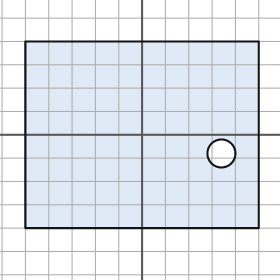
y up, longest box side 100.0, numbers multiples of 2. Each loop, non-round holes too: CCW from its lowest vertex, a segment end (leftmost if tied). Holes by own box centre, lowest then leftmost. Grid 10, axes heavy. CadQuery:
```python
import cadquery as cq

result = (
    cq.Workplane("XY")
    .moveTo(-50.0, -40.0)
    .lineTo(50.0, -40.0)
    .lineTo(50.0, 40.0)
    .lineTo(-50.0, 40.0)
    .close()
    .moveTo(34.0, -8.0)
    .circle(6.0)
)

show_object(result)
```